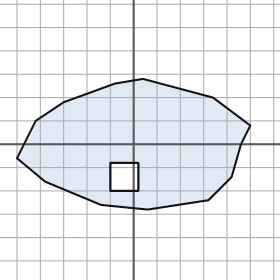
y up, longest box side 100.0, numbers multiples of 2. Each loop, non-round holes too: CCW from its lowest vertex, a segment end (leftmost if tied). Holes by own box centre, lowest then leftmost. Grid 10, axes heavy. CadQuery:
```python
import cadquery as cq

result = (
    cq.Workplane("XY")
    .moveTo(6.0, -28.0)
    .lineTo(32.0, -24.0)
    .lineTo(42.0, -14.0)
    .lineTo(46.0, 0.0)
    .lineTo(50.0, 8.0)
    .lineTo(34.0, 20.0)
    .lineTo(4.0, 28.0)
    .lineTo(-8.0, 26.0)
    .lineTo(-30.0, 18.0)
    .lineTo(-42.0, 10.0)
    .lineTo(-50.0, -6.0)
    .lineTo(-38.0, -16.0)
    .lineTo(-14.0, -26.0)
    .close()
    .moveTo(-10.0, -20.0)
    .lineTo(2.0, -20.0)
    .lineTo(2.0, -8.0)
    .lineTo(-10.0, -8.0)
    .close()
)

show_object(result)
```